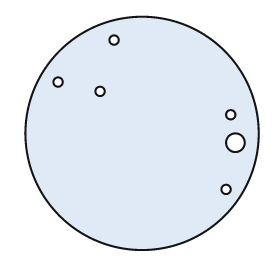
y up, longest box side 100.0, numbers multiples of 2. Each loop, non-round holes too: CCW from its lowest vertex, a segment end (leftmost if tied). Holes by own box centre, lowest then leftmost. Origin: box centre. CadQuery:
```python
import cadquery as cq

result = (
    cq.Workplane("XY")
    .moveTo(0.0, 0.0)
    .circle(50.0)
    .moveTo(36.0, -24.0)
    .circle(2.0)
    .moveTo(40.0, -4.0)
    .circle(4.0)
    .moveTo(38.0, 8.0)
    .circle(2.0)
    .moveTo(-18.0, 18.0)
    .circle(2.0)
    .moveTo(-36.0, 22.0)
    .circle(2.0)
    .moveTo(-12.0, 40.0)
    .circle(2.0)
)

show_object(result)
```